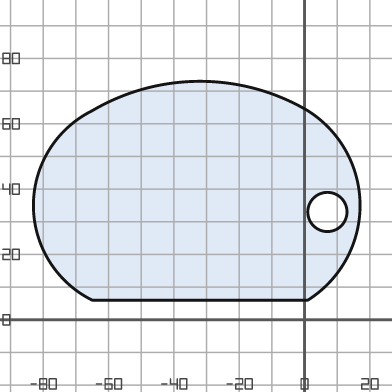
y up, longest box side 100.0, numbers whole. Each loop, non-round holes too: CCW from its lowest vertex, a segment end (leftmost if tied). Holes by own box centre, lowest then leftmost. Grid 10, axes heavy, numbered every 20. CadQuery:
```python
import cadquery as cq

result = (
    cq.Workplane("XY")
    .moveTo(-65.0, 6.0)
    .lineTo(1.0, 6.0)
    .threePointArc((17.0, 35.0), (1.0, 64.0))
    .threePointArc((-32.0, 73.0), (-65.0, 64.0))
    .threePointArc((-83.0, 35.0), (-65.0, 6.0))
    .close()
    .moveTo(7.0, 33.0)
    .circle(6.0)
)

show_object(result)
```